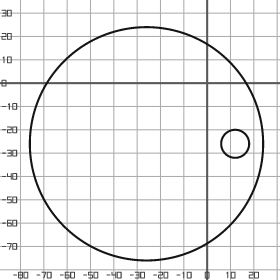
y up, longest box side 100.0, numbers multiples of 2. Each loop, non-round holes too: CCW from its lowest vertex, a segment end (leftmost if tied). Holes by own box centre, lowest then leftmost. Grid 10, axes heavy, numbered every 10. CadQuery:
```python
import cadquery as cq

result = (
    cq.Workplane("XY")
    .moveTo(-26.0, -26.0)
    .circle(50.0)
    .moveTo(12.0, -26.0)
    .circle(6.0)
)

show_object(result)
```